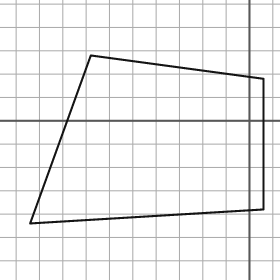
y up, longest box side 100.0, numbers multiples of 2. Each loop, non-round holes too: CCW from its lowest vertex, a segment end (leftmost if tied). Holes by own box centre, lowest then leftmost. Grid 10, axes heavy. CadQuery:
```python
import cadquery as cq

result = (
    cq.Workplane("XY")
    .moveTo(-94.0, -44.0)
    .lineTo(6.0, -38.0)
    .lineTo(6.0, 18.0)
    .lineTo(-68.0, 28.0)
    .close()
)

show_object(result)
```